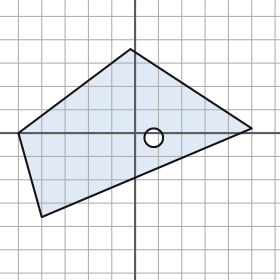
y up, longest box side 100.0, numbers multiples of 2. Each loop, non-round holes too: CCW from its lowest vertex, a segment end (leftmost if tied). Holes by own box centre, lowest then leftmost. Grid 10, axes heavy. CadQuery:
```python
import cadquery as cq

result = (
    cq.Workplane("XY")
    .moveTo(-40.0, -36.0)
    .lineTo(50.0, 2.0)
    .lineTo(-2.0, 36.0)
    .lineTo(-50.0, 0.0)
    .close()
    .moveTo(8.0, -2.0)
    .circle(4.0)
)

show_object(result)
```